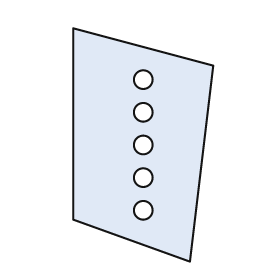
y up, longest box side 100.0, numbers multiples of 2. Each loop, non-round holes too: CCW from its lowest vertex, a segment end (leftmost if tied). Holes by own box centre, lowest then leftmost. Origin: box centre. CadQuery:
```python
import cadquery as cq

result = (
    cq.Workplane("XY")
    .moveTo(20.0, -50.0)
    .lineTo(30.0, 34.0)
    .lineTo(-30.0, 50.0)
    .lineTo(-30.0, -32.0)
    .close()
    .moveTo(0.0, -28.0)
    .circle(4.0)
    .moveTo(0.0, -14.0)
    .circle(4.0)
    .moveTo(0.0, 0.0)
    .circle(4.0)
    .moveTo(0.0, 14.0)
    .circle(4.0)
    .moveTo(0.0, 28.0)
    .circle(4.0)
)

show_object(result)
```